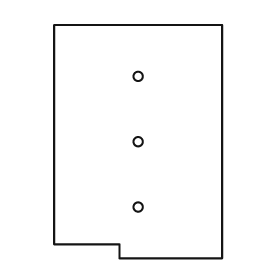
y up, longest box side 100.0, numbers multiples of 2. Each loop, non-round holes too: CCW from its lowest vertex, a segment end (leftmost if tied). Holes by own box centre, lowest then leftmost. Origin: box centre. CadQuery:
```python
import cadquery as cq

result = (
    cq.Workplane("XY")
    .moveTo(-8.0, -50.0)
    .lineTo(36.0, -50.0)
    .lineTo(36.0, 50.0)
    .lineTo(-36.0, 50.0)
    .lineTo(-36.0, -44.0)
    .lineTo(-8.0, -44.0)
    .close()
    .moveTo(0.0, -28.0)
    .circle(2.0)
    .moveTo(0.0, 0.0)
    .circle(2.0)
    .moveTo(0.0, 28.0)
    .circle(2.0)
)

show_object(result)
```